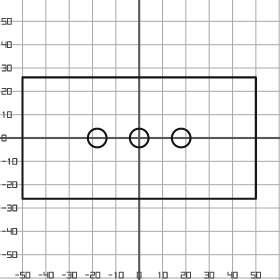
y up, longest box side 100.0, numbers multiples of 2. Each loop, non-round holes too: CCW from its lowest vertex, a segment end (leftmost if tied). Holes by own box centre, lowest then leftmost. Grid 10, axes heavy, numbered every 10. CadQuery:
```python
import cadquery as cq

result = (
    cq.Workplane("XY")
    .moveTo(-50.0, -26.0)
    .lineTo(50.0, -26.0)
    .lineTo(50.0, 26.0)
    .lineTo(-50.0, 26.0)
    .close()
    .moveTo(-18.0, 0.0)
    .circle(4.0)
    .moveTo(0.0, 0.0)
    .circle(4.0)
    .moveTo(18.0, 0.0)
    .circle(4.0)
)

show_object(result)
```